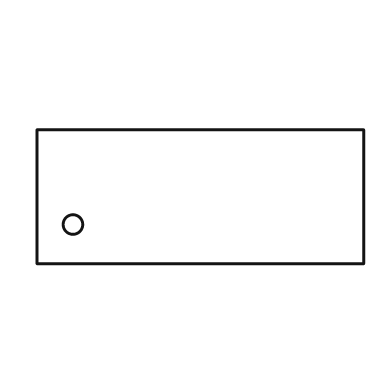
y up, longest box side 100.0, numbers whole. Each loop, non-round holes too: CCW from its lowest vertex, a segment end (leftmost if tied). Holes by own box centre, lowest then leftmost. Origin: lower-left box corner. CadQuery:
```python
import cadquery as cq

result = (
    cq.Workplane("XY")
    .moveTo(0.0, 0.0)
    .lineTo(100.0, 0.0)
    .lineTo(100.0, 41.0)
    .lineTo(0.0, 41.0)
    .close()
    .moveTo(11.0, 12.0)
    .circle(3.0)
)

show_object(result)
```